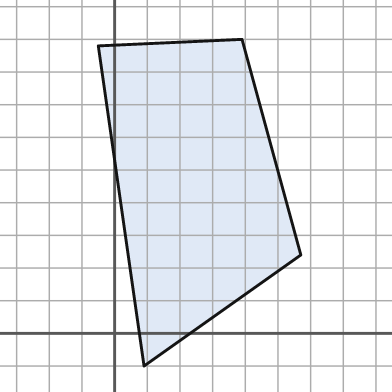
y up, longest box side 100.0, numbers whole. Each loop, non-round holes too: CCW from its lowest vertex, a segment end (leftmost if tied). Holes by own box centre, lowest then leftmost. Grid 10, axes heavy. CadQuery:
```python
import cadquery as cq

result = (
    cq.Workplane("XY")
    .moveTo(9.0, -10.0)
    .lineTo(57.0, 24.0)
    .lineTo(39.0, 90.0)
    .lineTo(-5.0, 88.0)
    .close()
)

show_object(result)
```